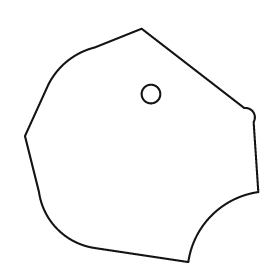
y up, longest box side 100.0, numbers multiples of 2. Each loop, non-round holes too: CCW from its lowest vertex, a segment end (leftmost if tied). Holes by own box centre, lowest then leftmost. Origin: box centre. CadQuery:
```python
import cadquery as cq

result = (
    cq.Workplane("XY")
    .moveTo(20.0, -50.0)
    .threePointArc((30.0, -30.0), (50.0, -20.0))
    .lineTo(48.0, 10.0)
    .threePointArc((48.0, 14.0), (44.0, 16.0))
    .lineTo(0.0, 50.0)
    .lineTo(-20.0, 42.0)
    .threePointArc((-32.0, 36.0), (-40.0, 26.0))
    .lineTo(-50.0, 4.0)
    .lineTo(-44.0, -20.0)
    .threePointArc((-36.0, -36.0), (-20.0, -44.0))
    .close()
    .moveTo(4.0, 22.0)
    .circle(4.0)
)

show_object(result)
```